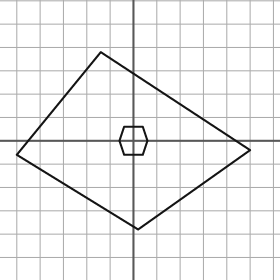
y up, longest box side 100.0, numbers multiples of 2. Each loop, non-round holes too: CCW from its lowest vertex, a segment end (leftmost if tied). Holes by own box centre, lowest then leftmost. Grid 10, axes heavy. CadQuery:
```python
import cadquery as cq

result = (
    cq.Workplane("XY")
    .moveTo(2.0, -38.0)
    .lineTo(50.0, -4.0)
    .lineTo(-14.0, 38.0)
    .lineTo(-50.0, -6.0)
    .close()
    .moveTo(-4.0, -6.0)
    .lineTo(4.0, -6.0)
    .lineTo(6.0, 0.0)
    .lineTo(4.0, 6.0)
    .lineTo(-4.0, 6.0)
    .lineTo(-6.0, 0.0)
    .close()
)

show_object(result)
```